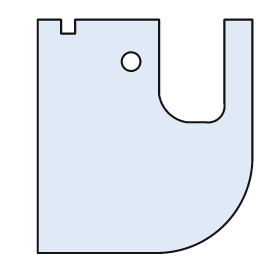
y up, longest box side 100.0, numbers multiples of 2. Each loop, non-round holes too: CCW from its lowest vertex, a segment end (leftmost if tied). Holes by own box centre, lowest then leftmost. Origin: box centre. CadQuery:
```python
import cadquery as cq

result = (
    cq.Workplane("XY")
    .moveTo(-46.0, -50.0)
    .lineTo(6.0, -50.0)
    .threePointArc((34.0, -38.0), (46.0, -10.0))
    .lineTo(46.0, 50.0)
    .lineTo(34.0, 50.0)
    .lineTo(34.0, 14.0)
    .threePointArc((32.0, 8.0), (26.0, 6.0))
    .lineTo(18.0, 6.0)
    .threePointArc((10.0, 10.0), (6.0, 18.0))
    .lineTo(6.0, 50.0)
    .lineTo(-30.0, 50.0)
    .lineTo(-30.0, 44.0)
    .lineTo(-36.0, 44.0)
    .lineTo(-36.0, 50.0)
    .lineTo(-46.0, 50.0)
    .close()
    .moveTo(-6.0, 32.0)
    .circle(4.0)
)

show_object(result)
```